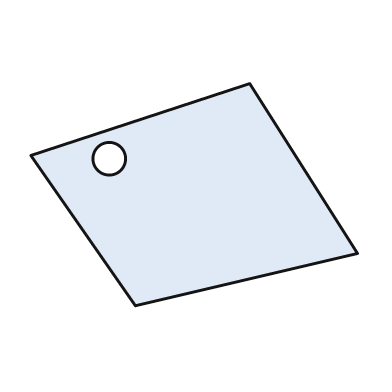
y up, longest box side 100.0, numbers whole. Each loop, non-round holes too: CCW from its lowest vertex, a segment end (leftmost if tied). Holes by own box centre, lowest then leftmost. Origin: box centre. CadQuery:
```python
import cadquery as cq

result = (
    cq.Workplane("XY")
    .moveTo(-18.0, -34.0)
    .lineTo(50.0, -18.0)
    .lineTo(17.0, 34.0)
    .lineTo(-50.0, 12.0)
    .close()
    .moveTo(-26.0, 11.0)
    .circle(5.0)
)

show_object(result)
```